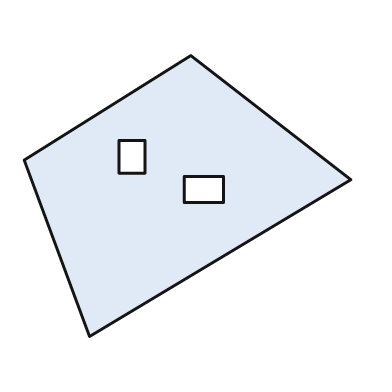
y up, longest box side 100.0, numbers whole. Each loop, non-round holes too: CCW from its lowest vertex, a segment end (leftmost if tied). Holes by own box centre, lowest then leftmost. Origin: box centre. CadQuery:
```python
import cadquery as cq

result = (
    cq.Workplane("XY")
    .moveTo(-30.0, -43.0)
    .lineTo(50.0, 5.0)
    .lineTo(1.0, 43.0)
    .lineTo(-50.0, 11.0)
    .close()
    .moveTo(-1.0, -2.0)
    .lineTo(11.0, -2.0)
    .lineTo(11.0, 6.0)
    .lineTo(-1.0, 6.0)
    .close()
    .moveTo(-21.0, 7.0)
    .lineTo(-13.0, 7.0)
    .lineTo(-13.0, 17.0)
    .lineTo(-21.0, 17.0)
    .close()
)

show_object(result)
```